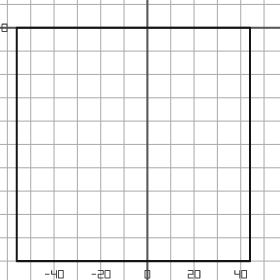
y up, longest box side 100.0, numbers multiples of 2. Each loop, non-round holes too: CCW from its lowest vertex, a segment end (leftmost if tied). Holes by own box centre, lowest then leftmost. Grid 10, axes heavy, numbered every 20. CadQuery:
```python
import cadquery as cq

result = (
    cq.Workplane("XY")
    .moveTo(-56.0, -100.0)
    .lineTo(44.0, -100.0)
    .lineTo(44.0, 0.0)
    .lineTo(-56.0, 0.0)
    .close()
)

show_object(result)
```